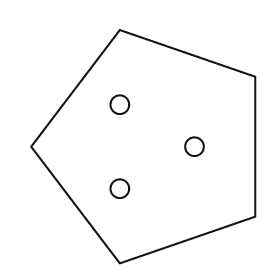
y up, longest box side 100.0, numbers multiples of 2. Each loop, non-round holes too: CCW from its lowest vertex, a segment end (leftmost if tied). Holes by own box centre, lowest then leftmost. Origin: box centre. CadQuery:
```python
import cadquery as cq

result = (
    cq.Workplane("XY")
    .moveTo(-10.0, -50.0)
    .lineTo(48.0, -30.0)
    .lineTo(48.0, 30.0)
    .lineTo(-10.0, 50.0)
    .lineTo(-48.0, 0.0)
    .close()
    .moveTo(-10.0, -18.0)
    .circle(4.0)
    .moveTo(22.0, 0.0)
    .circle(4.0)
    .moveTo(-10.0, 18.0)
    .circle(4.0)
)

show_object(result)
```